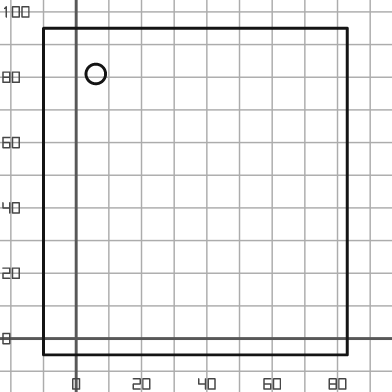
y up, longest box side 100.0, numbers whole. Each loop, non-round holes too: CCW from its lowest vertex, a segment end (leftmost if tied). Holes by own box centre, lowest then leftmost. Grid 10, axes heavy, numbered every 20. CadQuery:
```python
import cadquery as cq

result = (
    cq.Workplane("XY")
    .moveTo(-10.0, -5.0)
    .lineTo(83.0, -5.0)
    .lineTo(83.0, 95.0)
    .lineTo(-10.0, 95.0)
    .close()
    .moveTo(6.0, 81.0)
    .circle(3.0)
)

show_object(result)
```